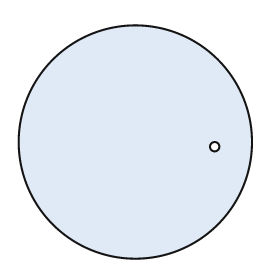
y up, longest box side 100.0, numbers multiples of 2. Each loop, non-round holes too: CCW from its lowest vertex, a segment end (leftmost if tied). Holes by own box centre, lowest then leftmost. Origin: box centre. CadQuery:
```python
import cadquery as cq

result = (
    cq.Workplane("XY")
    .moveTo(0.0, 0.0)
    .circle(50.0)
    .moveTo(34.0, -2.0)
    .circle(2.0)
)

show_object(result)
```